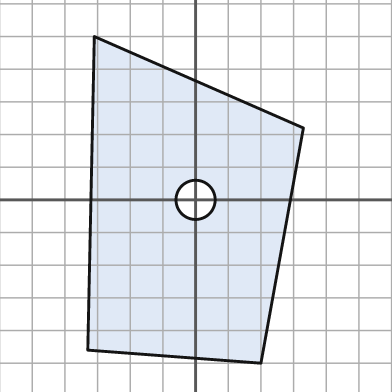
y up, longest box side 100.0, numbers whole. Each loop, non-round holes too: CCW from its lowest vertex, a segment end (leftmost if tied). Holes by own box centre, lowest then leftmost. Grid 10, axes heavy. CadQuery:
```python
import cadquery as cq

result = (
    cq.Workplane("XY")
    .moveTo(20.0, -50.0)
    .lineTo(33.0, 22.0)
    .lineTo(-31.0, 50.0)
    .lineTo(-33.0, -46.0)
    .close()
    .moveTo(0.0, 0.0)
    .circle(6.0)
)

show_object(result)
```